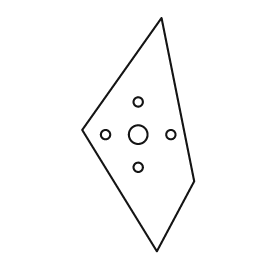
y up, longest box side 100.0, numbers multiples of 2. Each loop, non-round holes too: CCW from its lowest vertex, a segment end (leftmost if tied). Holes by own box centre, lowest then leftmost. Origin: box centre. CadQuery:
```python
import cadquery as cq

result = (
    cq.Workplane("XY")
    .moveTo(8.0, -50.0)
    .lineTo(24.0, -20.0)
    .lineTo(10.0, 50.0)
    .lineTo(-24.0, 2.0)
    .close()
    .moveTo(0.0, -14.0)
    .circle(2.0)
    .moveTo(-14.0, 0.0)
    .circle(2.0)
    .moveTo(0.0, 0.0)
    .circle(4.0)
    .moveTo(14.0, 0.0)
    .circle(2.0)
    .moveTo(0.0, 14.0)
    .circle(2.0)
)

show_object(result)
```